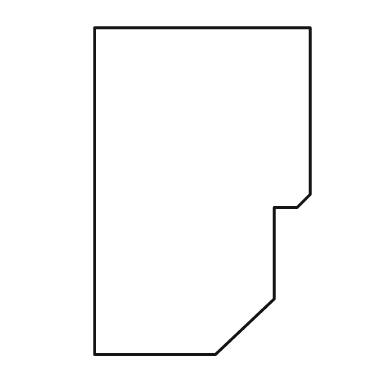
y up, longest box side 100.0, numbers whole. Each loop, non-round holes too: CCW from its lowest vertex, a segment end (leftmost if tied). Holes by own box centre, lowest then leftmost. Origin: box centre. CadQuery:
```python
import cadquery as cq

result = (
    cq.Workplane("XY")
    .moveTo(-33.0, -50.0)
    .lineTo(4.0, -50.0)
    .lineTo(22.0, -33.0)
    .lineTo(22.0, -5.0)
    .lineTo(29.0, -5.0)
    .lineTo(33.0, -1.0)
    .lineTo(33.0, 50.0)
    .lineTo(-33.0, 50.0)
    .close()
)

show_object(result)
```